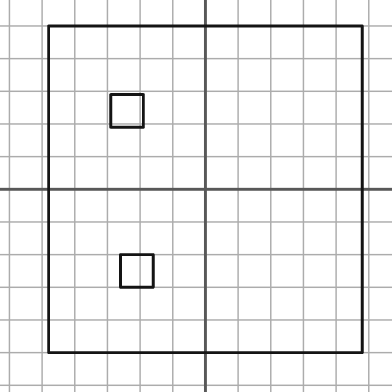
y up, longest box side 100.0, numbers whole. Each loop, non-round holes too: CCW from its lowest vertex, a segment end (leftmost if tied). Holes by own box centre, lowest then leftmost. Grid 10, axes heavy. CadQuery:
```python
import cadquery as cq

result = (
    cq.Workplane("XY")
    .moveTo(-48.0, -50.0)
    .lineTo(48.0, -50.0)
    .lineTo(48.0, 50.0)
    .lineTo(-48.0, 50.0)
    .close()
    .moveTo(-26.0, -30.0)
    .lineTo(-16.0, -30.0)
    .lineTo(-16.0, -20.0)
    .lineTo(-26.0, -20.0)
    .close()
    .moveTo(-29.0, 19.0)
    .lineTo(-19.0, 19.0)
    .lineTo(-19.0, 29.0)
    .lineTo(-29.0, 29.0)
    .close()
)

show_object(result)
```